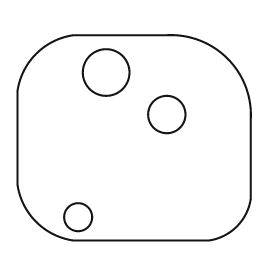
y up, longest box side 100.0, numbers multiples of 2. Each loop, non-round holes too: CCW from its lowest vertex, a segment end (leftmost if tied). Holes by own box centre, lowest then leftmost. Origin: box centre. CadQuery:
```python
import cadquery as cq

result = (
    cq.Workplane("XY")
    .moveTo(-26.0, -44.0)
    .lineTo(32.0, -44.0)
    .threePointArc((44.0, -38.0), (50.0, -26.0))
    .lineTo(50.0, 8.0)
    .threePointArc((40.0, 34.0), (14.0, 44.0))
    .lineTo(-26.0, 44.0)
    .threePointArc((-42.0, 36.0), (-50.0, 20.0))
    .lineTo(-50.0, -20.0)
    .threePointArc((-42.0, -36.0), (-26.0, -44.0))
    .close()
    .moveTo(-24.0, -34.0)
    .circle(6.0)
    .moveTo(14.0, 10.0)
    .circle(8.0)
    .moveTo(-12.0, 28.0)
    .circle(10.0)
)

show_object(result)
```